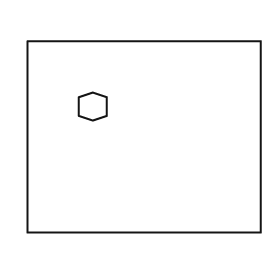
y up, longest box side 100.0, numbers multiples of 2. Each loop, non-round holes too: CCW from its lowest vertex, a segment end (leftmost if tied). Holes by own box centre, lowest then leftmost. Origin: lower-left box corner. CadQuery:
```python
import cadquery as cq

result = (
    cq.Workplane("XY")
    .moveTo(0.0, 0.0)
    .lineTo(100.0, 0.0)
    .lineTo(100.0, 82.0)
    .lineTo(0.0, 82.0)
    .close()
    .moveTo(28.0, 48.0)
    .lineTo(34.0, 50.0)
    .lineTo(34.0, 58.0)
    .lineTo(28.0, 60.0)
    .lineTo(22.0, 58.0)
    .lineTo(22.0, 50.0)
    .close()
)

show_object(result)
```